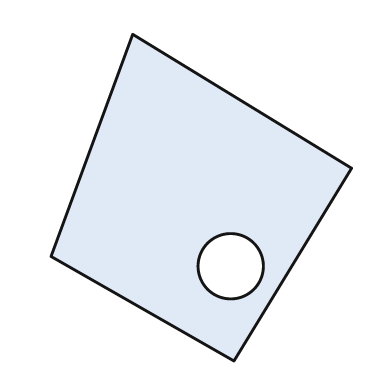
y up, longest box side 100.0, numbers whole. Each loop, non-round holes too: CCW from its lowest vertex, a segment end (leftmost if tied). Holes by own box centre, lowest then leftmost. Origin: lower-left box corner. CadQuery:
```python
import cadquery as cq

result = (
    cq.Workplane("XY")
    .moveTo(56.0, 0.0)
    .lineTo(92.0, 59.0)
    .lineTo(25.0, 100.0)
    .lineTo(0.0, 32.0)
    .close()
    .moveTo(55.0, 29.0)
    .circle(10.0)
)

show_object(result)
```